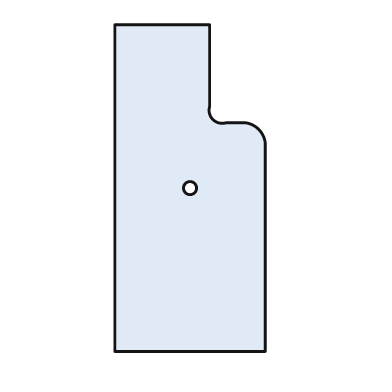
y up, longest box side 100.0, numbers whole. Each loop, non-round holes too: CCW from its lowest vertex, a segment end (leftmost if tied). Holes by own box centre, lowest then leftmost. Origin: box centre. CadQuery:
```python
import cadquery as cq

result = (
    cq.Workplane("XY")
    .moveTo(-23.0, -50.0)
    .lineTo(23.0, -50.0)
    .lineTo(23.0, 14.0)
    .threePointArc((21.0, 18.0), (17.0, 20.0))
    .lineTo(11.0, 20.0)
    .threePointArc((7.0, 21.0), (6.0, 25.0))
    .lineTo(6.0, 50.0)
    .lineTo(-23.0, 50.0)
    .close()
    .moveTo(0.0, 0.0)
    .circle(2.0)
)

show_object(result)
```